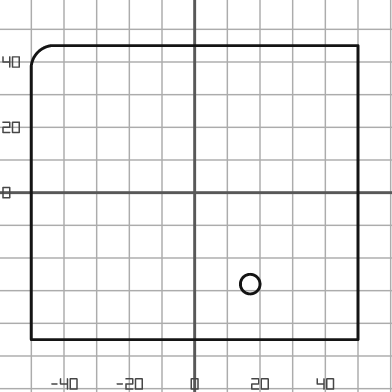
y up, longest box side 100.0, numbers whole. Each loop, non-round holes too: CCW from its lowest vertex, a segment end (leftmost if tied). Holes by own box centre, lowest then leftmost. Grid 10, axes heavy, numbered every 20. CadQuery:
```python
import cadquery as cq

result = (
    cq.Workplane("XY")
    .moveTo(-50.0, -45.0)
    .lineTo(50.0, -45.0)
    .lineTo(50.0, 45.0)
    .lineTo(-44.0, 45.0)
    .threePointArc((-48.0, 43.0), (-50.0, 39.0))
    .close()
    .moveTo(17.0, -28.0)
    .circle(3.0)
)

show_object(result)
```